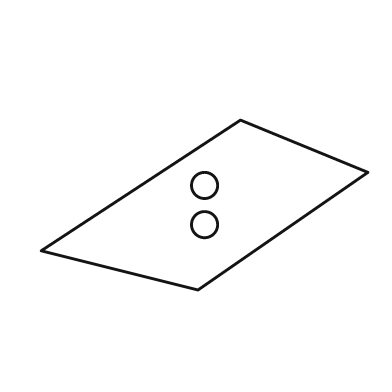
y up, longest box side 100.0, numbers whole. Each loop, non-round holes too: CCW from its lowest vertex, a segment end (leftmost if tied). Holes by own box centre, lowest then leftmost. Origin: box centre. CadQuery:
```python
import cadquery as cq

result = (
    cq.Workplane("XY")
    .moveTo(-2.0, -26.0)
    .lineTo(50.0, 10.0)
    .lineTo(11.0, 26.0)
    .lineTo(-50.0, -14.0)
    .close()
    .moveTo(0.0, -6.0)
    .circle(4.0)
    .moveTo(0.0, 6.0)
    .circle(4.0)
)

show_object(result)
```